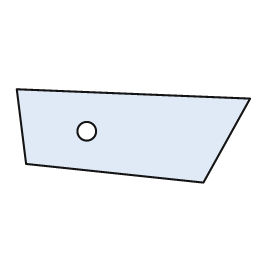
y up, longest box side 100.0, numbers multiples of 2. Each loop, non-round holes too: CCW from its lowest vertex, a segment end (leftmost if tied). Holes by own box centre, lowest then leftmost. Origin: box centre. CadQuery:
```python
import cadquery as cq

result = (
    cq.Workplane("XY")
    .moveTo(30.0, -20.0)
    .lineTo(50.0, 16.0)
    .lineTo(-50.0, 20.0)
    .lineTo(-46.0, -12.0)
    .close()
    .moveTo(-20.0, 2.0)
    .circle(4.0)
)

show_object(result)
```